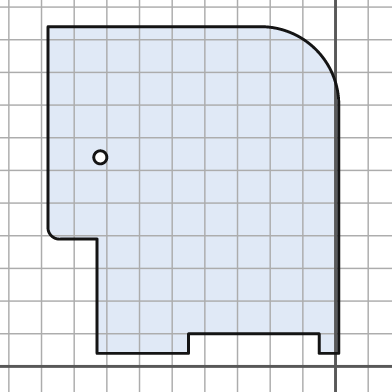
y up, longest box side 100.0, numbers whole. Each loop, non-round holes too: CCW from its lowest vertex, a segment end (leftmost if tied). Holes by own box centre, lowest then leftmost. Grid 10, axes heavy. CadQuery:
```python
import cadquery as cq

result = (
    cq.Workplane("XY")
    .moveTo(-73.0, 4.0)
    .lineTo(-45.0, 4.0)
    .lineTo(-45.0, 10.0)
    .lineTo(-5.0, 10.0)
    .lineTo(-5.0, 4.0)
    .lineTo(1.0, 4.0)
    .lineTo(1.0, 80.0)
    .threePointArc((-6.0, 97.0), (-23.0, 104.0))
    .lineTo(-88.0, 104.0)
    .lineTo(-88.0, 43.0)
    .threePointArc((-87.0, 40.0), (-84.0, 39.0))
    .lineTo(-73.0, 39.0)
    .close()
    .moveTo(-72.0, 64.0)
    .circle(2.0)
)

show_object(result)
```